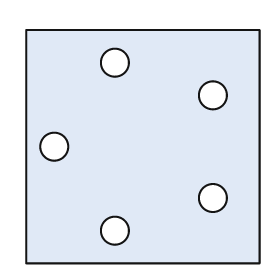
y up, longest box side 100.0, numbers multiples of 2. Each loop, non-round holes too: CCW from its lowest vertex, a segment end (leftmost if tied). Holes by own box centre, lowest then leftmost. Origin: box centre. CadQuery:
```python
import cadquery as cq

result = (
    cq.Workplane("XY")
    .moveTo(-50.0, -50.0)
    .lineTo(50.0, -50.0)
    .lineTo(50.0, 50.0)
    .lineTo(-50.0, 50.0)
    .close()
    .moveTo(-12.0, -36.0)
    .circle(6.0)
    .moveTo(30.0, -22.0)
    .circle(6.0)
    .moveTo(-38.0, 0.0)
    .circle(6.0)
    .moveTo(30.0, 22.0)
    .circle(6.0)
    .moveTo(-12.0, 36.0)
    .circle(6.0)
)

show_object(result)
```